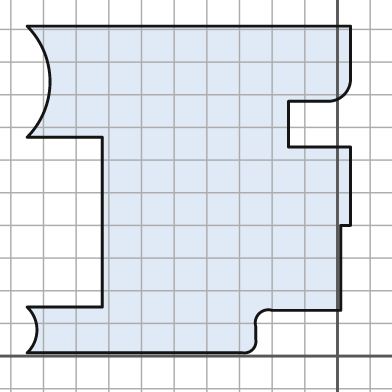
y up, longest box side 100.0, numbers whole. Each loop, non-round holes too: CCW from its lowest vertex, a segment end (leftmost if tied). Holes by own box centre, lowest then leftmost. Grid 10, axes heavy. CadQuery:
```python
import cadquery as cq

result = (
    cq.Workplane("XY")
    .moveTo(-95.0, 1.0)
    .lineTo(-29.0, 1.0)
    .threePointArc((-26.0, 2.0), (-25.0, 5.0))
    .lineTo(-25.0, 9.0)
    .threePointArc((-24.0, 13.0), (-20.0, 14.0))
    .lineTo(1.0, 14.0)
    .lineTo(1.0, 40.0)
    .lineTo(4.0, 40.0)
    .lineTo(4.0, 64.0)
    .lineTo(-15.0, 64.0)
    .lineTo(-15.0, 78.0)
    .lineTo(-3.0, 78.0)
    .threePointArc((2.0, 80.0), (4.0, 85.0))
    .lineTo(4.0, 101.0)
    .lineTo(-95.0, 101.0)
    .threePointArc((-88.0, 84.0), (-95.0, 67.0))
    .lineTo(-72.0, 67.0)
    .lineTo(-72.0, 15.0)
    .lineTo(-95.0, 15.0)
    .threePointArc((-92.0, 8.0), (-95.0, 1.0))
    .close()
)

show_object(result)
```